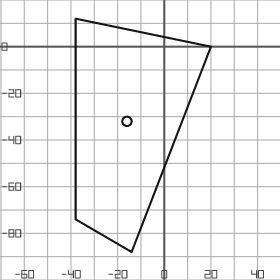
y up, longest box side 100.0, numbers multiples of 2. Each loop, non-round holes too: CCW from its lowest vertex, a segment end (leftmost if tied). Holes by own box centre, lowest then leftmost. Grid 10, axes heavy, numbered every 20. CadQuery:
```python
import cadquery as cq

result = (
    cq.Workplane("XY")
    .moveTo(-14.0, -88.0)
    .lineTo(20.0, 0.0)
    .lineTo(-38.0, 12.0)
    .lineTo(-38.0, -74.0)
    .close()
    .moveTo(-16.0, -32.0)
    .circle(2.0)
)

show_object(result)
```